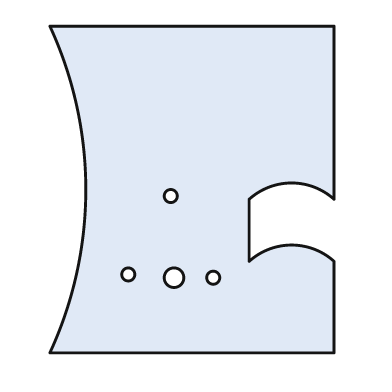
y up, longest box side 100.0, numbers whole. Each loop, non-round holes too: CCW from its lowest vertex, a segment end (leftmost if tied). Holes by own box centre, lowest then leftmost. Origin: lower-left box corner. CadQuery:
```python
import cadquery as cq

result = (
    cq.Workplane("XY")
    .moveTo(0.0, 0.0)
    .lineTo(87.0, 0.0)
    .lineTo(87.0, 28.0)
    .threePointArc((74.0, 33.0), (61.0, 28.0))
    .lineTo(61.0, 47.0)
    .threePointArc((74.0, 52.0), (87.0, 47.0))
    .lineTo(87.0, 100.0)
    .lineTo(0.0, 100.0)
    .threePointArc((11.0, 50.0), (0.0, 0.0))
    .close()
    .moveTo(38.0, 23.0)
    .circle(3.0)
    .moveTo(50.0, 23.0)
    .circle(2.0)
    .moveTo(24.0, 24.0)
    .circle(2.0)
    .moveTo(37.0, 48.0)
    .circle(2.0)
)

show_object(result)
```